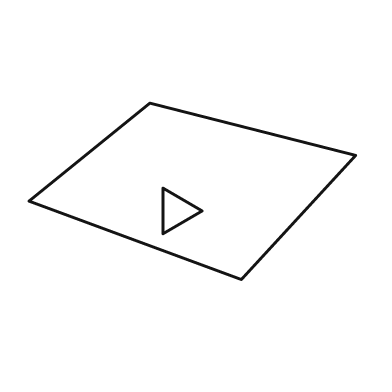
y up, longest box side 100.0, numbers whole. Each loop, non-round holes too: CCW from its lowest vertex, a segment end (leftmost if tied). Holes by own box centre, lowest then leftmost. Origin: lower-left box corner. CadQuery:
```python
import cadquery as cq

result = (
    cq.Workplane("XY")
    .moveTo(65.0, 0.0)
    .lineTo(100.0, 38.0)
    .lineTo(37.0, 54.0)
    .lineTo(0.0, 24.0)
    .close()
    .moveTo(41.0, 14.0)
    .lineTo(53.0, 21.0)
    .lineTo(41.0, 28.0)
    .close()
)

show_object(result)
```